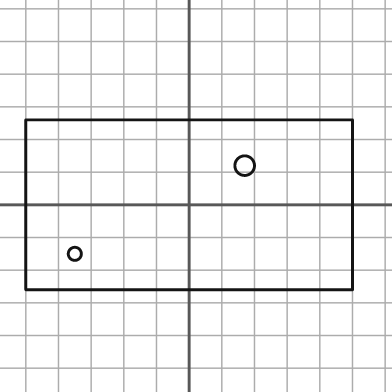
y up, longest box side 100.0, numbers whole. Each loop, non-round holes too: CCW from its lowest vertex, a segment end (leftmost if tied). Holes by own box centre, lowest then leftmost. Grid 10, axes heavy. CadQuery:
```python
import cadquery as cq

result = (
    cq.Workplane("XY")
    .moveTo(-50.0, -26.0)
    .lineTo(50.0, -26.0)
    .lineTo(50.0, 26.0)
    .lineTo(-50.0, 26.0)
    .close()
    .moveTo(-35.0, -15.0)
    .circle(2.0)
    .moveTo(17.0, 12.0)
    .circle(3.0)
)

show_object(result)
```